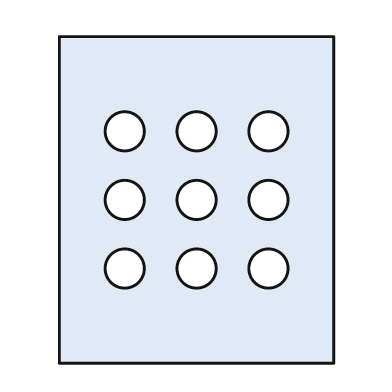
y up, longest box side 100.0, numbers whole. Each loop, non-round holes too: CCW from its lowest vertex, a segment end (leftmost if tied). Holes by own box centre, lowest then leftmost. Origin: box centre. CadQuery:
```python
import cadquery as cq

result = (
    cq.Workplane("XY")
    .moveTo(-42.0, -50.0)
    .lineTo(42.0, -50.0)
    .lineTo(42.0, 50.0)
    .lineTo(-42.0, 50.0)
    .close()
    .moveTo(-22.0, -21.0)
    .circle(6.0)
    .moveTo(0.0, -21.0)
    .circle(6.0)
    .moveTo(22.0, -21.0)
    .circle(6.0)
    .moveTo(-22.0, 0.0)
    .circle(6.0)
    .moveTo(0.0, 0.0)
    .circle(6.0)
    .moveTo(22.0, 0.0)
    .circle(6.0)
    .moveTo(-22.0, 21.0)
    .circle(6.0)
    .moveTo(0.0, 21.0)
    .circle(6.0)
    .moveTo(22.0, 21.0)
    .circle(6.0)
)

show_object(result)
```